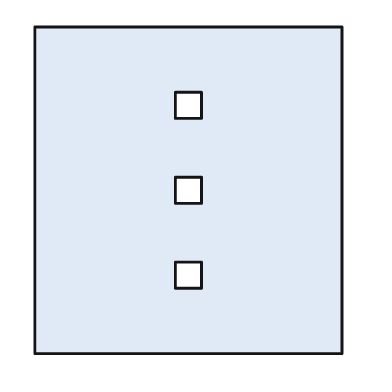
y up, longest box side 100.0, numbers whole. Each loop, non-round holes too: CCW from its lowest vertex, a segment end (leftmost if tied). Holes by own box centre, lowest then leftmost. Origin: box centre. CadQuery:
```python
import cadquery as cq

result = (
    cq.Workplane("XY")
    .moveTo(-47.0, -50.0)
    .lineTo(47.0, -50.0)
    .lineTo(47.0, 50.0)
    .lineTo(-47.0, 50.0)
    .close()
    .moveTo(-4.0, -30.0)
    .lineTo(4.0, -30.0)
    .lineTo(4.0, -22.0)
    .lineTo(-4.0, -22.0)
    .close()
    .moveTo(-4.0, -4.0)
    .lineTo(4.0, -4.0)
    .lineTo(4.0, 4.0)
    .lineTo(-4.0, 4.0)
    .close()
    .moveTo(-4.0, 22.0)
    .lineTo(4.0, 22.0)
    .lineTo(4.0, 30.0)
    .lineTo(-4.0, 30.0)
    .close()
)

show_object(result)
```